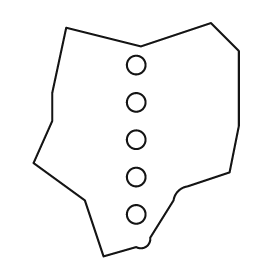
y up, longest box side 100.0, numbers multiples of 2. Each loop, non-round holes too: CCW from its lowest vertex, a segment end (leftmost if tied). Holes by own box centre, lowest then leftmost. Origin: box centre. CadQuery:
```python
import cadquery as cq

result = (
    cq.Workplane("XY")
    .moveTo(-14.0, -50.0)
    .lineTo(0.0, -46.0)
    .threePointArc((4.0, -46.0), (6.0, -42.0))
    .lineTo(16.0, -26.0)
    .threePointArc((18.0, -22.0), (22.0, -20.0))
    .lineTo(40.0, -14.0)
    .lineTo(44.0, 6.0)
    .lineTo(44.0, 38.0)
    .lineTo(32.0, 50.0)
    .lineTo(2.0, 40.0)
    .lineTo(-30.0, 48.0)
    .lineTo(-36.0, 20.0)
    .lineTo(-36.0, 8.0)
    .lineTo(-44.0, -10.0)
    .lineTo(-22.0, -26.0)
    .close()
    .moveTo(0.0, -32.0)
    .circle(4.0)
    .moveTo(0.0, -16.0)
    .circle(4.0)
    .moveTo(0.0, 0.0)
    .circle(4.0)
    .moveTo(0.0, 16.0)
    .circle(4.0)
    .moveTo(0.0, 32.0)
    .circle(4.0)
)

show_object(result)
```